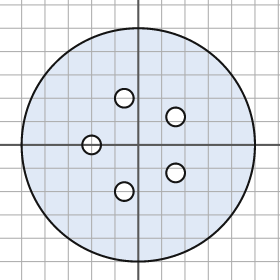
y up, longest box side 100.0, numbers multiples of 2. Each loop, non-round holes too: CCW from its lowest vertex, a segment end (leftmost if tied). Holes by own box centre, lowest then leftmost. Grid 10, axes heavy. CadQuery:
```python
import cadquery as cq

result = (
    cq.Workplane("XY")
    .moveTo(0.0, 0.0)
    .circle(50.0)
    .moveTo(-6.0, -20.0)
    .circle(4.0)
    .moveTo(16.0, -12.0)
    .circle(4.0)
    .moveTo(-20.0, 0.0)
    .circle(4.0)
    .moveTo(16.0, 12.0)
    .circle(4.0)
    .moveTo(-6.0, 20.0)
    .circle(4.0)
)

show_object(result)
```